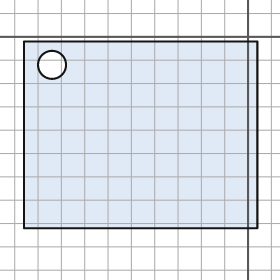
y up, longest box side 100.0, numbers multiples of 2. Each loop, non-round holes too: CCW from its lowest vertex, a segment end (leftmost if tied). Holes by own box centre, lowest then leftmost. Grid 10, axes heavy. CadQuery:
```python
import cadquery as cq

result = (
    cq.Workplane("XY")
    .moveTo(-96.0, -82.0)
    .lineTo(4.0, -82.0)
    .lineTo(4.0, -2.0)
    .lineTo(-96.0, -2.0)
    .close()
    .moveTo(-84.0, -12.0)
    .circle(6.0)
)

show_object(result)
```